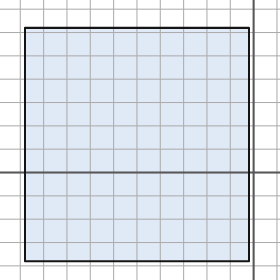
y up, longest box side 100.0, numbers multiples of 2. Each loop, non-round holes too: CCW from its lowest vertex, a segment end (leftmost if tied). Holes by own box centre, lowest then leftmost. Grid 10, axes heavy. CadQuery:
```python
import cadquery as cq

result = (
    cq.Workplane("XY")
    .moveTo(-98.0, -38.0)
    .lineTo(-2.0, -38.0)
    .lineTo(-2.0, 62.0)
    .lineTo(-98.0, 62.0)
    .close()
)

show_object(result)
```